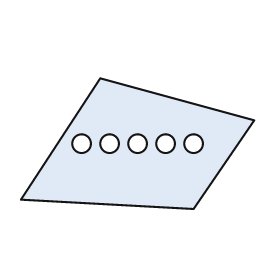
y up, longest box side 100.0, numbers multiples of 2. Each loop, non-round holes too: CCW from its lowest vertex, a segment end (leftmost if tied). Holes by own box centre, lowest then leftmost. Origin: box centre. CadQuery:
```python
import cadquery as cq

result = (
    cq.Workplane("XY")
    .moveTo(24.0, -28.0)
    .lineTo(50.0, 10.0)
    .lineTo(-16.0, 28.0)
    .lineTo(-50.0, -24.0)
    .close()
    .moveTo(-24.0, 0.0)
    .circle(4.0)
    .moveTo(-12.0, 0.0)
    .circle(4.0)
    .moveTo(0.0, 0.0)
    .circle(4.0)
    .moveTo(12.0, 0.0)
    .circle(4.0)
    .moveTo(24.0, 0.0)
    .circle(4.0)
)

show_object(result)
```